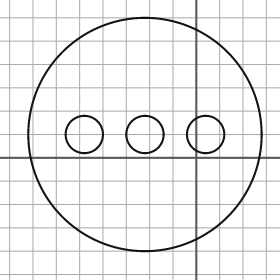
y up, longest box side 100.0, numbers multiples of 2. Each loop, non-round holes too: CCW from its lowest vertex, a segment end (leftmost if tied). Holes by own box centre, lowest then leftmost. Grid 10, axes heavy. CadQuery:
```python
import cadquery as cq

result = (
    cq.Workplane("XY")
    .moveTo(-22.0, 10.0)
    .circle(50.0)
    .moveTo(-48.0, 10.0)
    .circle(8.0)
    .moveTo(-22.0, 10.0)
    .circle(8.0)
    .moveTo(4.0, 10.0)
    .circle(8.0)
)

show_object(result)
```